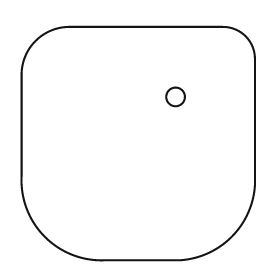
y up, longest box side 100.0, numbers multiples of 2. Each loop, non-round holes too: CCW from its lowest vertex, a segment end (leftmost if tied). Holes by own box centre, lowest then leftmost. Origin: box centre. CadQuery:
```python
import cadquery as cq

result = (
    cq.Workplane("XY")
    .moveTo(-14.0, -50.0)
    .lineTo(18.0, -50.0)
    .threePointArc((40.0, -40.0), (50.0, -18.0))
    .lineTo(50.0, 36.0)
    .threePointArc((46.0, 46.0), (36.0, 50.0))
    .lineTo(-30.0, 50.0)
    .threePointArc((-44.0, 44.0), (-50.0, 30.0))
    .lineTo(-50.0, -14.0)
    .threePointArc((-40.0, -40.0), (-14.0, -50.0))
    .close()
    .moveTo(16.0, 20.0)
    .circle(4.0)
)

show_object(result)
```